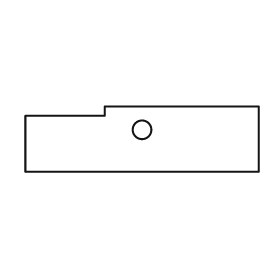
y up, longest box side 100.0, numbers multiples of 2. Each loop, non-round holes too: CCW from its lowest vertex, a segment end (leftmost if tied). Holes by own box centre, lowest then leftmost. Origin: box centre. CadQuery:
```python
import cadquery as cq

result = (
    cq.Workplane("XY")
    .moveTo(-50.0, -14.0)
    .lineTo(50.0, -14.0)
    .lineTo(50.0, 14.0)
    .lineTo(-16.0, 14.0)
    .lineTo(-16.0, 10.0)
    .lineTo(-50.0, 10.0)
    .close()
    .moveTo(0.0, 4.0)
    .circle(4.0)
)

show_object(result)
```